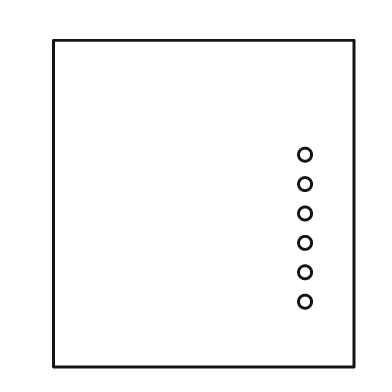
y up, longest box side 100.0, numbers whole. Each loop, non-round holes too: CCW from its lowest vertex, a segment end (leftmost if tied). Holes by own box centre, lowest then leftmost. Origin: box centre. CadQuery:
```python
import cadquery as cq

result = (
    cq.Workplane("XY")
    .moveTo(-46.0, -50.0)
    .lineTo(46.0, -50.0)
    .lineTo(46.0, 50.0)
    .lineTo(-46.0, 50.0)
    .close()
    .moveTo(31.0, -30.0)
    .circle(2.0)
    .moveTo(31.0, -21.0)
    .circle(2.0)
    .moveTo(31.0, -12.0)
    .circle(2.0)
    .moveTo(31.0, -3.0)
    .circle(2.0)
    .moveTo(31.0, 6.0)
    .circle(2.0)
    .moveTo(31.0, 15.0)
    .circle(2.0)
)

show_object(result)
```